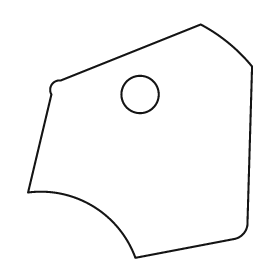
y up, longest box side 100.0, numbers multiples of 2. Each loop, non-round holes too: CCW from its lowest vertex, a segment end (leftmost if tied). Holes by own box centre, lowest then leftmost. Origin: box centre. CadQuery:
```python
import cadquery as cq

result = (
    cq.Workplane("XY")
    .moveTo(-2.0, -50.0)
    .lineTo(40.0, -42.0)
    .threePointArc((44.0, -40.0), (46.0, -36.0))
    .lineTo(48.0, 32.0)
    .threePointArc((38.0, 42.0), (26.0, 50.0))
    .lineTo(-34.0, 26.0)
    .threePointArc((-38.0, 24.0), (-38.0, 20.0))
    .lineTo(-48.0, -22.0)
    .threePointArc((-20.0, -28.0), (-2.0, -50.0))
    .close()
    .moveTo(0.0, 20.0)
    .circle(8.0)
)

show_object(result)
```